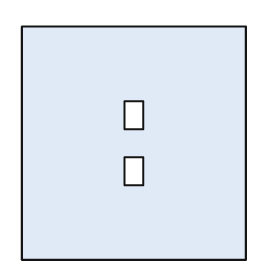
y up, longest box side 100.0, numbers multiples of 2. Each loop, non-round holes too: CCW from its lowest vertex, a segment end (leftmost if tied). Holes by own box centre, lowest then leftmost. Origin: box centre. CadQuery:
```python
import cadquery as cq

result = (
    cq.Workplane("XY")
    .moveTo(-48.0, -50.0)
    .lineTo(48.0, -50.0)
    .lineTo(48.0, 50.0)
    .lineTo(-48.0, 50.0)
    .close()
    .moveTo(-4.0, -18.0)
    .lineTo(4.0, -18.0)
    .lineTo(4.0, -6.0)
    .lineTo(-4.0, -6.0)
    .close()
    .moveTo(-4.0, 6.0)
    .lineTo(4.0, 6.0)
    .lineTo(4.0, 18.0)
    .lineTo(-4.0, 18.0)
    .close()
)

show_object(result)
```